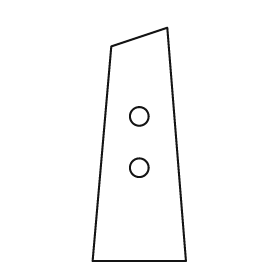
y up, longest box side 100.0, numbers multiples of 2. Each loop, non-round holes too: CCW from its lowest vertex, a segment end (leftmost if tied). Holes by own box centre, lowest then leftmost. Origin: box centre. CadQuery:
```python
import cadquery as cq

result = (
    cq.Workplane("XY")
    .moveTo(-20.0, -50.0)
    .lineTo(20.0, -50.0)
    .lineTo(12.0, 50.0)
    .lineTo(-12.0, 42.0)
    .close()
    .moveTo(0.0, -10.0)
    .circle(4.0)
    .moveTo(0.0, 12.0)
    .circle(4.0)
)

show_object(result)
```